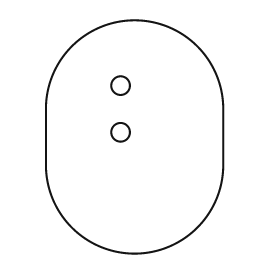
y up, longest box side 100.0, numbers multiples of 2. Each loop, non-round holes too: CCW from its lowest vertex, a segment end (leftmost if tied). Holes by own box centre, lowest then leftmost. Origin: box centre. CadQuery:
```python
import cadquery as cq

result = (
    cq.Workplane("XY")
    .moveTo(-38.0, -12.0)
    .threePointArc((0.0, -50.0), (38.0, -12.0))
    .lineTo(38.0, 12.0)
    .threePointArc((0.0, 50.0), (-38.0, 12.0))
    .close()
    .moveTo(-6.0, 2.0)
    .circle(4.0)
    .moveTo(-6.0, 22.0)
    .circle(4.0)
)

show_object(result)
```